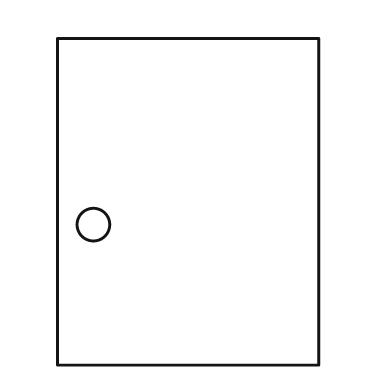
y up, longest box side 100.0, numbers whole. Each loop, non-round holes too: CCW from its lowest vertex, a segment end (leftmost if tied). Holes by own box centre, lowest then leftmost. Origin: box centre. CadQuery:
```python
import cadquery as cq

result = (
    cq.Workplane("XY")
    .moveTo(-40.0, -50.0)
    .lineTo(40.0, -50.0)
    .lineTo(40.0, 50.0)
    .lineTo(-40.0, 50.0)
    .close()
    .moveTo(-29.0, -7.0)
    .circle(5.0)
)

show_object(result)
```